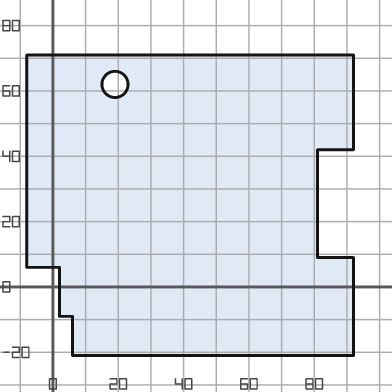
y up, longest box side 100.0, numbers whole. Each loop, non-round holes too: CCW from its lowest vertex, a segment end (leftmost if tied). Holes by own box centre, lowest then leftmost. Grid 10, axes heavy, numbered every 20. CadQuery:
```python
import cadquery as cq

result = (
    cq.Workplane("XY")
    .moveTo(6.0, -21.0)
    .lineTo(92.0, -21.0)
    .lineTo(92.0, 9.0)
    .lineTo(81.0, 9.0)
    .lineTo(81.0, 42.0)
    .lineTo(92.0, 42.0)
    .lineTo(92.0, 71.0)
    .lineTo(-8.0, 71.0)
    .lineTo(-8.0, 6.0)
    .lineTo(2.0, 6.0)
    .lineTo(2.0, -9.0)
    .lineTo(6.0, -9.0)
    .close()
    .moveTo(19.0, 62.0)
    .circle(4.0)
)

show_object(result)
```